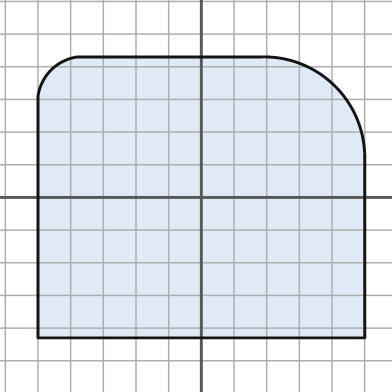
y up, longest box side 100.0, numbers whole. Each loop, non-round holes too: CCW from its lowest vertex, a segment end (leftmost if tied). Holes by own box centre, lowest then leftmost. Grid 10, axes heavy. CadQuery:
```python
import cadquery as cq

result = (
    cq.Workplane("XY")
    .moveTo(-50.0, -43.0)
    .lineTo(50.0, -43.0)
    .lineTo(50.0, 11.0)
    .threePointArc((41.0, 34.0), (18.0, 43.0))
    .lineTo(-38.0, 43.0)
    .threePointArc((-46.0, 39.0), (-50.0, 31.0))
    .close()
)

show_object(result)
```